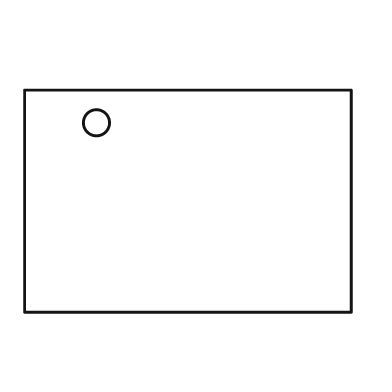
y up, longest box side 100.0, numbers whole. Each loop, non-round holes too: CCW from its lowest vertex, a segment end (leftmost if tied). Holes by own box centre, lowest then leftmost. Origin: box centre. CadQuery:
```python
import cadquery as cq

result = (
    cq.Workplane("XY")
    .moveTo(-50.0, -34.0)
    .lineTo(50.0, -34.0)
    .lineTo(50.0, 34.0)
    .lineTo(-50.0, 34.0)
    .close()
    .moveTo(-28.0, 24.0)
    .circle(4.0)
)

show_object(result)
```